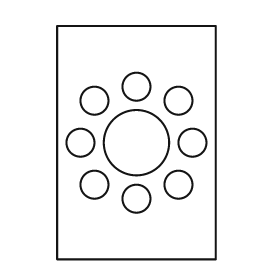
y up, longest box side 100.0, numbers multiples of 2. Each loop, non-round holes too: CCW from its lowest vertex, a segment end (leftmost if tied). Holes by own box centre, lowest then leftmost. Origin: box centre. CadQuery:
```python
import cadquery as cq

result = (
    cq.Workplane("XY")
    .moveTo(-34.0, -50.0)
    .lineTo(34.0, -50.0)
    .lineTo(34.0, 50.0)
    .lineTo(-34.0, 50.0)
    .close()
    .moveTo(0.0, -24.0)
    .circle(6.0)
    .moveTo(-18.0, -18.0)
    .circle(6.0)
    .moveTo(18.0, -18.0)
    .circle(6.0)
    .moveTo(-24.0, 0.0)
    .circle(6.0)
    .moveTo(0.0, 0.0)
    .circle(14.0)
    .moveTo(24.0, 0.0)
    .circle(6.0)
    .moveTo(-18.0, 18.0)
    .circle(6.0)
    .moveTo(18.0, 18.0)
    .circle(6.0)
    .moveTo(0.0, 24.0)
    .circle(6.0)
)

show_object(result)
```